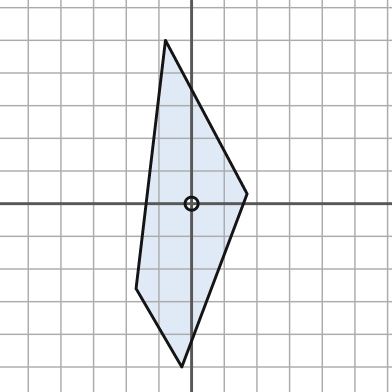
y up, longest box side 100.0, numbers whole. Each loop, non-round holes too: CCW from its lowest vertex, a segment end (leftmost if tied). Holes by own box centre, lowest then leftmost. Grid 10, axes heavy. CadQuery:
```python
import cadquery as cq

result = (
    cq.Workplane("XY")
    .moveTo(-3.0, -50.0)
    .lineTo(17.0, 3.0)
    .lineTo(-8.0, 50.0)
    .lineTo(-17.0, -26.0)
    .close()
    .moveTo(0.0, 0.0)
    .circle(2.0)
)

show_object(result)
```